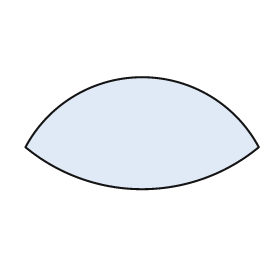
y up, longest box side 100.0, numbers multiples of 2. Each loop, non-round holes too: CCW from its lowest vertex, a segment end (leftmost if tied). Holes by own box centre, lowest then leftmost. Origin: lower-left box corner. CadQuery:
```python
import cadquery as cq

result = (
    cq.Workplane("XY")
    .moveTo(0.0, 18.0)
    .threePointArc((50.0, 0.0), (100.0, 18.0))
    .threePointArc((50.0, 48.0), (0.0, 18.0))
    .close()
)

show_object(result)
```